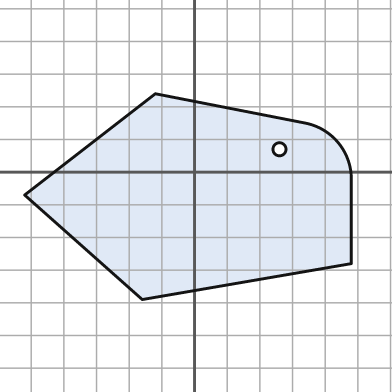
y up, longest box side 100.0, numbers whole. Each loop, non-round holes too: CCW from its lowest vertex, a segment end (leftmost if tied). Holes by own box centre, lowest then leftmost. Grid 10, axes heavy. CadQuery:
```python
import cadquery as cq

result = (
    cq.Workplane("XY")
    .moveTo(-16.0, -39.0)
    .lineTo(48.0, -28.0)
    .lineTo(48.0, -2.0)
    .threePointArc((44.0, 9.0), (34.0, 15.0))
    .lineTo(-12.0, 24.0)
    .lineTo(-52.0, -7.0)
    .close()
    .moveTo(26.0, 7.0)
    .circle(2.0)
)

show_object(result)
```